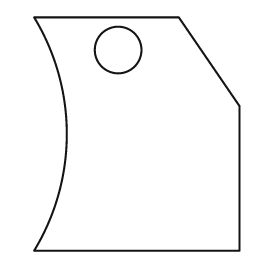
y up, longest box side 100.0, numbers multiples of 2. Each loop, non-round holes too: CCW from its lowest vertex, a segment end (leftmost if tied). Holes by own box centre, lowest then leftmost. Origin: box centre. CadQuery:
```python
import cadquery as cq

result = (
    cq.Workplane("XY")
    .moveTo(-44.0, -50.0)
    .lineTo(44.0, -50.0)
    .lineTo(44.0, 12.0)
    .lineTo(18.0, 50.0)
    .lineTo(-44.0, 50.0)
    .threePointArc((-30.0, 0.0), (-44.0, -50.0))
    .close()
    .moveTo(-8.0, 36.0)
    .circle(10.0)
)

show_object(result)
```